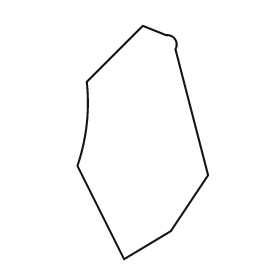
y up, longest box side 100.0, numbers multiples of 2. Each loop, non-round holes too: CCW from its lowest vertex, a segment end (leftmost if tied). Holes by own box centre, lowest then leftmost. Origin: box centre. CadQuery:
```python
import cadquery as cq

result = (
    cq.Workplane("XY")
    .moveTo(-8.0, -50.0)
    .lineTo(12.0, -38.0)
    .lineTo(28.0, -14.0)
    .lineTo(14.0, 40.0)
    .threePointArc((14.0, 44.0), (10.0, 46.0))
    .lineTo(0.0, 50.0)
    .lineTo(-24.0, 26.0)
    .threePointArc((-24.0, 8.0), (-28.0, -10.0))
    .close()
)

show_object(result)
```